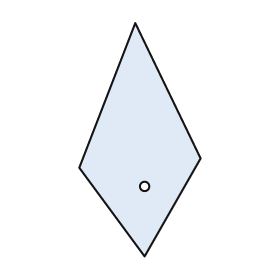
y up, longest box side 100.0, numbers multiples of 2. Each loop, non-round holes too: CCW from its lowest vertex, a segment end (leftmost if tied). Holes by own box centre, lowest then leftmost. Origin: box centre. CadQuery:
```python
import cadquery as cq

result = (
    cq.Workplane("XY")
    .moveTo(2.0, -50.0)
    .lineTo(26.0, -8.0)
    .lineTo(-2.0, 50.0)
    .lineTo(-26.0, -12.0)
    .close()
    .moveTo(2.0, -20.0)
    .circle(2.0)
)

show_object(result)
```